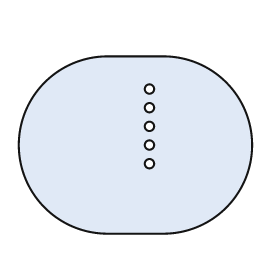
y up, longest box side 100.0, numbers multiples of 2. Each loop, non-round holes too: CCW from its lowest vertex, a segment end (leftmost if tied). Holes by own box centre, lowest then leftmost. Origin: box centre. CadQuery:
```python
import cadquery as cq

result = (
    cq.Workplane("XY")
    .moveTo(-12.0, -38.0)
    .lineTo(12.0, -38.0)
    .threePointArc((50.0, 0.0), (12.0, 38.0))
    .lineTo(-12.0, 38.0)
    .threePointArc((-50.0, 0.0), (-12.0, -38.0))
    .close()
    .moveTo(6.0, -8.0)
    .circle(2.0)
    .moveTo(6.0, 0.0)
    .circle(2.0)
    .moveTo(6.0, 8.0)
    .circle(2.0)
    .moveTo(6.0, 16.0)
    .circle(2.0)
    .moveTo(6.0, 24.0)
    .circle(2.0)
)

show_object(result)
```